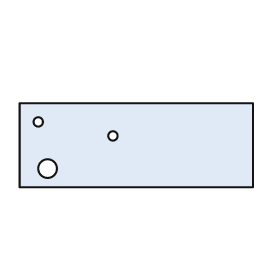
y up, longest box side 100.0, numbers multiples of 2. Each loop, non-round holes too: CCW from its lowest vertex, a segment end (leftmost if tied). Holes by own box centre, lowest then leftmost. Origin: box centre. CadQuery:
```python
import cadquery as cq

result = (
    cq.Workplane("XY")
    .moveTo(-50.0, -18.0)
    .lineTo(50.0, -18.0)
    .lineTo(50.0, 18.0)
    .lineTo(-50.0, 18.0)
    .close()
    .moveTo(-38.0, -10.0)
    .circle(4.0)
    .moveTo(-10.0, 4.0)
    .circle(2.0)
    .moveTo(-42.0, 10.0)
    .circle(2.0)
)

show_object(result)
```